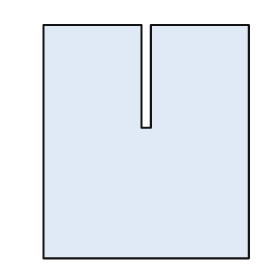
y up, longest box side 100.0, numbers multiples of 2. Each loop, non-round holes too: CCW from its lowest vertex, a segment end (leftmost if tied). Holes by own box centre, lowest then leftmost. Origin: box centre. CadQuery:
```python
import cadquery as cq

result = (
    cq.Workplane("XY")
    .moveTo(-44.0, -50.0)
    .lineTo(44.0, -50.0)
    .lineTo(44.0, 50.0)
    .lineTo(2.0, 50.0)
    .lineTo(2.0, 6.0)
    .lineTo(-2.0, 6.0)
    .lineTo(-2.0, 50.0)
    .lineTo(-44.0, 50.0)
    .close()
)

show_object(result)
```